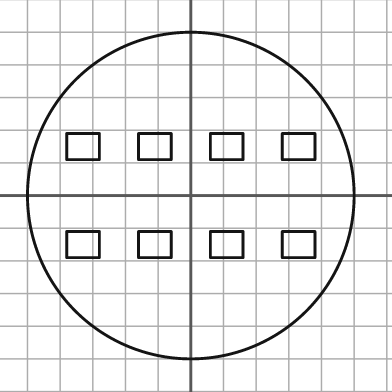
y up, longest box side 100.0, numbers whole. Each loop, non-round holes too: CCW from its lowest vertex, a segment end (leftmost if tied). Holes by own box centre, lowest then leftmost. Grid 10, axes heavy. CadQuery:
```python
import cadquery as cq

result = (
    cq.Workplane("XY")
    .moveTo(0.0, 0.0)
    .circle(50.0)
    .moveTo(-38.0, -19.0)
    .lineTo(-28.0, -19.0)
    .lineTo(-28.0, -11.0)
    .lineTo(-38.0, -11.0)
    .close()
    .moveTo(-16.0, -19.0)
    .lineTo(-6.0, -19.0)
    .lineTo(-6.0, -11.0)
    .lineTo(-16.0, -11.0)
    .close()
    .moveTo(6.0, -19.0)
    .lineTo(16.0, -19.0)
    .lineTo(16.0, -11.0)
    .lineTo(6.0, -11.0)
    .close()
    .moveTo(28.0, -19.0)
    .lineTo(38.0, -19.0)
    .lineTo(38.0, -11.0)
    .lineTo(28.0, -11.0)
    .close()
    .moveTo(-38.0, 11.0)
    .lineTo(-28.0, 11.0)
    .lineTo(-28.0, 19.0)
    .lineTo(-38.0, 19.0)
    .close()
    .moveTo(-16.0, 11.0)
    .lineTo(-6.0, 11.0)
    .lineTo(-6.0, 19.0)
    .lineTo(-16.0, 19.0)
    .close()
    .moveTo(6.0, 11.0)
    .lineTo(16.0, 11.0)
    .lineTo(16.0, 19.0)
    .lineTo(6.0, 19.0)
    .close()
    .moveTo(28.0, 11.0)
    .lineTo(38.0, 11.0)
    .lineTo(38.0, 19.0)
    .lineTo(28.0, 19.0)
    .close()
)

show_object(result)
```